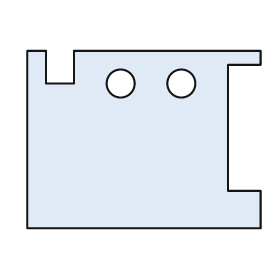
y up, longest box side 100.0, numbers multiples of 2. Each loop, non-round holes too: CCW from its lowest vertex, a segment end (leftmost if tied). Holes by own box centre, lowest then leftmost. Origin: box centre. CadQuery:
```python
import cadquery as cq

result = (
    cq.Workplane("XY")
    .moveTo(-50.0, -38.0)
    .lineTo(50.0, -38.0)
    .lineTo(50.0, -22.0)
    .lineTo(36.0, -22.0)
    .lineTo(36.0, 32.0)
    .lineTo(50.0, 32.0)
    .lineTo(50.0, 38.0)
    .lineTo(-30.0, 38.0)
    .lineTo(-30.0, 24.0)
    .lineTo(-42.0, 24.0)
    .lineTo(-42.0, 38.0)
    .lineTo(-50.0, 38.0)
    .close()
    .moveTo(-10.0, 24.0)
    .circle(6.0)
    .moveTo(16.0, 24.0)
    .circle(6.0)
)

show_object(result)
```